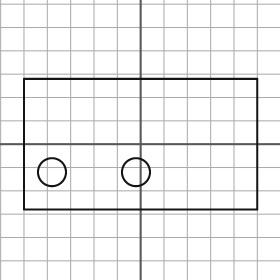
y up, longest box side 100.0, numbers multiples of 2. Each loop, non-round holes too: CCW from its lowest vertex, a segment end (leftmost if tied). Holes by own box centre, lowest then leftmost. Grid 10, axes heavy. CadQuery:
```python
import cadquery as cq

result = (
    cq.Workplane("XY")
    .moveTo(-50.0, -28.0)
    .lineTo(50.0, -28.0)
    .lineTo(50.0, 28.0)
    .lineTo(-50.0, 28.0)
    .close()
    .moveTo(-38.0, -12.0)
    .circle(6.0)
    .moveTo(-2.0, -12.0)
    .circle(6.0)
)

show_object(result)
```